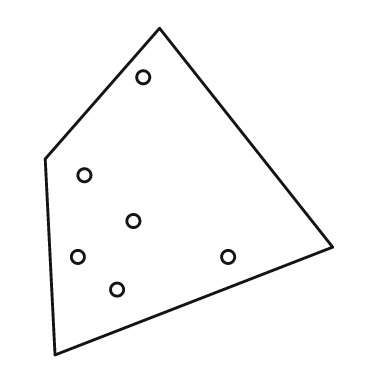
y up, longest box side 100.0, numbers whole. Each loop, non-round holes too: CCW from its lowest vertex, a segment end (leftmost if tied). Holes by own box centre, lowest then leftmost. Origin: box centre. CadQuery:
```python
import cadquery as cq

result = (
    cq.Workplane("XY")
    .moveTo(-41.0, -50.0)
    .lineTo(44.0, -17.0)
    .lineTo(-9.0, 50.0)
    .lineTo(-44.0, 10.0)
    .close()
    .moveTo(-22.0, -30.0)
    .circle(2.0)
    .moveTo(-34.0, -20.0)
    .circle(2.0)
    .moveTo(12.0, -20.0)
    .circle(2.0)
    .moveTo(-17.0, -9.0)
    .circle(2.0)
    .moveTo(-32.0, 5.0)
    .circle(2.0)
    .moveTo(-14.0, 35.0)
    .circle(2.0)
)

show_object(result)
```